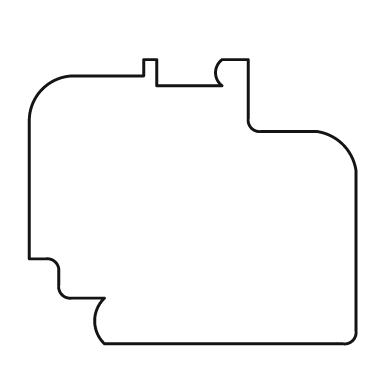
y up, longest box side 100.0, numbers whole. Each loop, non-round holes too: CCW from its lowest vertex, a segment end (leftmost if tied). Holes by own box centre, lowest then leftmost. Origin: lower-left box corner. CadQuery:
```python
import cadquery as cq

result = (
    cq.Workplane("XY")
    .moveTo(23.0, 0.0)
    .lineTo(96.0, 0.0)
    .threePointArc((99.0, 1.0), (100.0, 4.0))
    .lineTo(100.0, 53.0)
    .threePointArc((96.0, 61.0), (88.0, 65.0))
    .lineTo(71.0, 65.0)
    .threePointArc((68.0, 66.0), (67.0, 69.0))
    .lineTo(67.0, 87.0)
    .lineTo(59.0, 87.0)
    .threePointArc((57.0, 83.0), (59.0, 79.0))
    .lineTo(39.0, 79.0)
    .lineTo(39.0, 87.0)
    .lineTo(35.0, 87.0)
    .lineTo(35.0, 82.0)
    .lineTo(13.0, 82.0)
    .threePointArc((4.0, 78.0), (0.0, 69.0))
    .lineTo(0.0, 26.0)
    .lineTo(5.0, 26.0)
    .threePointArc((8.0, 25.0), (9.0, 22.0))
    .lineTo(9.0, 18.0)
    .threePointArc((10.0, 15.0), (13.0, 14.0))
    .lineTo(23.0, 14.0)
    .threePointArc((20.0, 7.0), (23.0, 0.0))
    .close()
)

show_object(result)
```